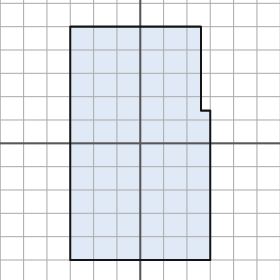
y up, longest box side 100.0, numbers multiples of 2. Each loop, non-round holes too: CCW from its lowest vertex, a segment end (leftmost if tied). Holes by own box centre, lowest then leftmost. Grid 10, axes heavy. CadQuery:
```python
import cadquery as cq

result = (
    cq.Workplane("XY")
    .moveTo(-30.0, -50.0)
    .lineTo(30.0, -50.0)
    .lineTo(30.0, 14.0)
    .lineTo(26.0, 14.0)
    .lineTo(26.0, 50.0)
    .lineTo(-30.0, 50.0)
    .close()
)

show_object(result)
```